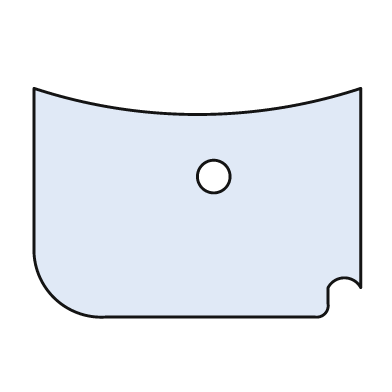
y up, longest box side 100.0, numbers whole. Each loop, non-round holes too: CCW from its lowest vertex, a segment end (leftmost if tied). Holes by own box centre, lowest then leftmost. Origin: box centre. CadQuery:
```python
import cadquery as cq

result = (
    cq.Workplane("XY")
    .moveTo(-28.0, -35.0)
    .lineTo(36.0, -35.0)
    .threePointArc((39.0, -34.0), (40.0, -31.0))
    .lineTo(40.0, -26.0)
    .threePointArc((45.0, -23.0), (50.0, -26.0))
    .lineTo(50.0, 35.0)
    .threePointArc((0.0, 27.0), (-50.0, 35.0))
    .lineTo(-50.0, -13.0)
    .threePointArc((-44.0, -29.0), (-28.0, -35.0))
    .close()
    .moveTo(5.0, 8.0)
    .circle(5.0)
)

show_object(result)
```